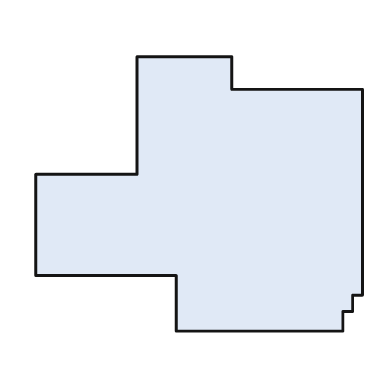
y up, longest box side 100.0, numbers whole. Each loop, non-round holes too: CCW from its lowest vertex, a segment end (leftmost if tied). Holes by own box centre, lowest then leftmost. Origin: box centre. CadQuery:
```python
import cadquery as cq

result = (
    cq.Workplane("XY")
    .moveTo(-7.0, -42.0)
    .lineTo(44.0, -42.0)
    .lineTo(44.0, -36.0)
    .lineTo(47.0, -36.0)
    .lineTo(47.0, -31.0)
    .lineTo(50.0, -31.0)
    .lineTo(50.0, 32.0)
    .lineTo(10.0, 32.0)
    .lineTo(10.0, 42.0)
    .lineTo(-19.0, 42.0)
    .lineTo(-19.0, 6.0)
    .lineTo(-50.0, 6.0)
    .lineTo(-50.0, -25.0)
    .lineTo(-7.0, -25.0)
    .close()
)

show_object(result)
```